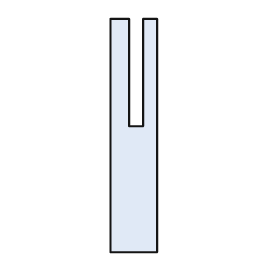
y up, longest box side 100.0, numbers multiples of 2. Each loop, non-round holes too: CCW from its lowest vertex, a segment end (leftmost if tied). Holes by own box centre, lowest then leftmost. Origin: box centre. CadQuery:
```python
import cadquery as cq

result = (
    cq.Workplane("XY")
    .moveTo(-10.0, -50.0)
    .lineTo(10.0, -50.0)
    .lineTo(10.0, 50.0)
    .lineTo(4.0, 50.0)
    .lineTo(4.0, 4.0)
    .lineTo(-2.0, 4.0)
    .lineTo(-2.0, 50.0)
    .lineTo(-10.0, 50.0)
    .close()
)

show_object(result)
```